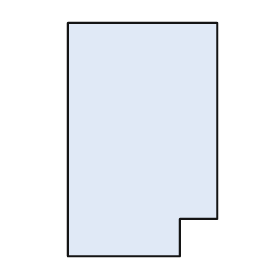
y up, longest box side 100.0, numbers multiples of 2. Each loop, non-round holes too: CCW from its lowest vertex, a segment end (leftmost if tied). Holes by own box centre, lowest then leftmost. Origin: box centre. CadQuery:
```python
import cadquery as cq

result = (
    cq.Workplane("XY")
    .moveTo(-32.0, -50.0)
    .lineTo(16.0, -50.0)
    .lineTo(16.0, -34.0)
    .lineTo(32.0, -34.0)
    .lineTo(32.0, 50.0)
    .lineTo(-32.0, 50.0)
    .close()
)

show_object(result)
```